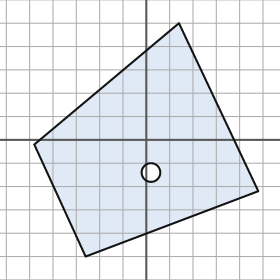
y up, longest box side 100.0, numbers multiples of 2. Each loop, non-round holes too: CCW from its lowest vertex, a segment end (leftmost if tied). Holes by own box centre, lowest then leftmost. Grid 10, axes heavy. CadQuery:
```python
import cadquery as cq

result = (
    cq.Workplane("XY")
    .moveTo(-26.0, -50.0)
    .lineTo(48.0, -22.0)
    .lineTo(14.0, 50.0)
    .lineTo(-48.0, -2.0)
    .close()
    .moveTo(2.0, -14.0)
    .circle(4.0)
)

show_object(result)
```